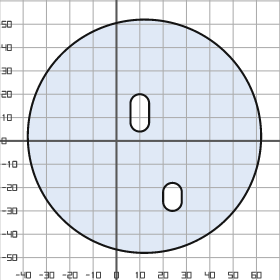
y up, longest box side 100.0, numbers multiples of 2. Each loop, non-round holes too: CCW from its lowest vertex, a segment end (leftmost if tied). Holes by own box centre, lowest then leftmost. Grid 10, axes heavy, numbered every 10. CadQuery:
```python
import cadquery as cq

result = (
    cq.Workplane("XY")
    .moveTo(12.0, 2.0)
    .circle(50.0)
    .moveTo(20.0, -26.0)
    .threePointArc((24.0, -30.0), (28.0, -26.0))
    .lineTo(28.0, -22.0)
    .threePointArc((24.0, -18.0), (20.0, -22.0))
    .close()
    .moveTo(6.0, 8.0)
    .threePointArc((10.0, 4.0), (14.0, 8.0))
    .lineTo(14.0, 16.0)
    .threePointArc((10.0, 20.0), (6.0, 16.0))
    .close()
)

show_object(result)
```